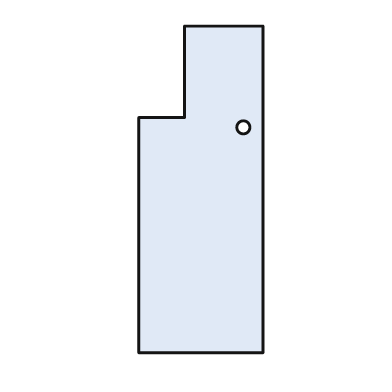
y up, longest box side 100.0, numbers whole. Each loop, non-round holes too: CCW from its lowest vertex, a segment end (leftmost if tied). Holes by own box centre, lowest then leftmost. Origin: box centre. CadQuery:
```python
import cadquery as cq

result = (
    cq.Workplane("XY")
    .moveTo(-19.0, -50.0)
    .lineTo(19.0, -50.0)
    .lineTo(19.0, 50.0)
    .lineTo(-5.0, 50.0)
    .lineTo(-5.0, 22.0)
    .lineTo(-19.0, 22.0)
    .close()
    .moveTo(13.0, 19.0)
    .circle(2.0)
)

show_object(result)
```